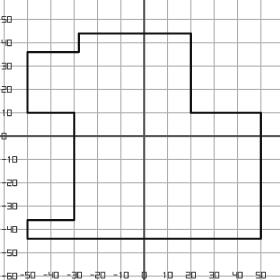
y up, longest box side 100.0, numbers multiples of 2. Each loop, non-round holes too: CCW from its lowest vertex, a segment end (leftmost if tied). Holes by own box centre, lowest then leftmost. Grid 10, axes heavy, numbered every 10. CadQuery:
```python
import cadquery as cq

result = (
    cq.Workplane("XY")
    .moveTo(-50.0, -44.0)
    .lineTo(50.0, -44.0)
    .lineTo(50.0, 10.0)
    .lineTo(20.0, 10.0)
    .lineTo(20.0, 44.0)
    .lineTo(-28.0, 44.0)
    .lineTo(-28.0, 36.0)
    .lineTo(-50.0, 36.0)
    .lineTo(-50.0, 10.0)
    .lineTo(-30.0, 10.0)
    .lineTo(-30.0, -36.0)
    .lineTo(-50.0, -36.0)
    .close()
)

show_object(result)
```